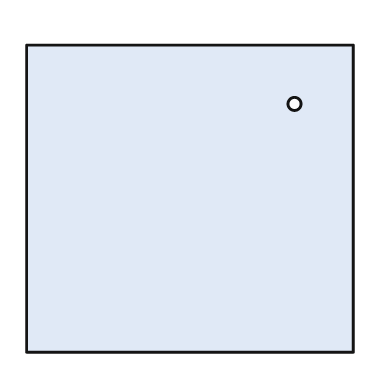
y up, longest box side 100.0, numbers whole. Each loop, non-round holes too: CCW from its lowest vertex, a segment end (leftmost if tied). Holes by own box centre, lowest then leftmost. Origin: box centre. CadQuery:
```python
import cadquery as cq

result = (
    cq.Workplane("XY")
    .moveTo(-50.0, -47.0)
    .lineTo(50.0, -47.0)
    .lineTo(50.0, 47.0)
    .lineTo(-50.0, 47.0)
    .close()
    .moveTo(32.0, 29.0)
    .circle(2.0)
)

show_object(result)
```